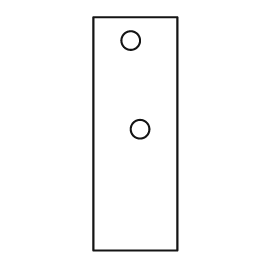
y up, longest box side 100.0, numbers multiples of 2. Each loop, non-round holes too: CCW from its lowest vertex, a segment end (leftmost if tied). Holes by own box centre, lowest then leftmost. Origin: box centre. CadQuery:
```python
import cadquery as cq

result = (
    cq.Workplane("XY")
    .moveTo(-18.0, -50.0)
    .lineTo(18.0, -50.0)
    .lineTo(18.0, 50.0)
    .lineTo(-18.0, 50.0)
    .close()
    .moveTo(2.0, 2.0)
    .circle(4.0)
    .moveTo(-2.0, 40.0)
    .circle(4.0)
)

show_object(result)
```